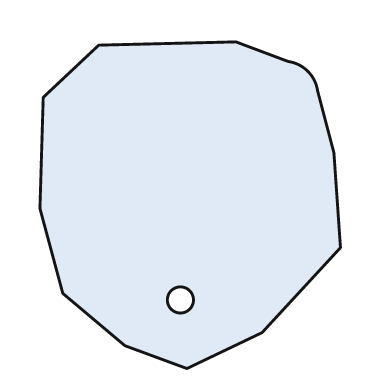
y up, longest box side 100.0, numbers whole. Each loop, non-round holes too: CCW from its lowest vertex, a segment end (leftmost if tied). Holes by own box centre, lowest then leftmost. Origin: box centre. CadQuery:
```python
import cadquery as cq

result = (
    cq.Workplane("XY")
    .moveTo(-1.0, -50.0)
    .lineTo(22.0, -39.0)
    .lineTo(46.0, -13.0)
    .lineTo(44.0, 16.0)
    .lineTo(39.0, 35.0)
    .threePointArc((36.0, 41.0), (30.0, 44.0))
    .lineTo(14.0, 50.0)
    .lineTo(-28.0, 49.0)
    .lineTo(-45.0, 33.0)
    .lineTo(-46.0, -1.0)
    .lineTo(-39.0, -27.0)
    .lineTo(-20.0, -43.0)
    .close()
    .moveTo(-3.0, -29.0)
    .circle(4.0)
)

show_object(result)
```